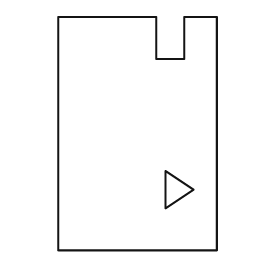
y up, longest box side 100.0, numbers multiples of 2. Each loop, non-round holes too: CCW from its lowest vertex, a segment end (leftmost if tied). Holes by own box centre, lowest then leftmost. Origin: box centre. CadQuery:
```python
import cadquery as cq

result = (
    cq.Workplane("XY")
    .moveTo(-34.0, -50.0)
    .lineTo(34.0, -50.0)
    .lineTo(34.0, 50.0)
    .lineTo(20.0, 50.0)
    .lineTo(20.0, 32.0)
    .lineTo(8.0, 32.0)
    .lineTo(8.0, 50.0)
    .lineTo(-34.0, 50.0)
    .close()
    .moveTo(12.0, -32.0)
    .lineTo(24.0, -24.0)
    .lineTo(12.0, -16.0)
    .close()
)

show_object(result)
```